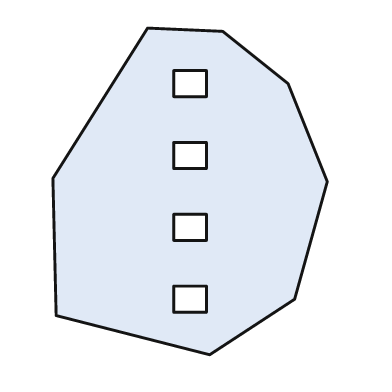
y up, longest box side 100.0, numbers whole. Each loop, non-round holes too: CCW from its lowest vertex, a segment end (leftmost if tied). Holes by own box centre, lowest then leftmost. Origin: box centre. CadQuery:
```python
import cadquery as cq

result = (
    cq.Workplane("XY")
    .moveTo(6.0, -50.0)
    .lineTo(32.0, -33.0)
    .lineTo(42.0, 3.0)
    .lineTo(30.0, 33.0)
    .lineTo(10.0, 49.0)
    .lineTo(-13.0, 50.0)
    .lineTo(-42.0, 4.0)
    .lineTo(-41.0, -38.0)
    .close()
    .moveTo(-5.0, -37.0)
    .lineTo(5.0, -37.0)
    .lineTo(5.0, -29.0)
    .lineTo(-5.0, -29.0)
    .close()
    .moveTo(-5.0, -15.0)
    .lineTo(5.0, -15.0)
    .lineTo(5.0, -7.0)
    .lineTo(-5.0, -7.0)
    .close()
    .moveTo(-5.0, 7.0)
    .lineTo(5.0, 7.0)
    .lineTo(5.0, 15.0)
    .lineTo(-5.0, 15.0)
    .close()
    .moveTo(-5.0, 29.0)
    .lineTo(5.0, 29.0)
    .lineTo(5.0, 37.0)
    .lineTo(-5.0, 37.0)
    .close()
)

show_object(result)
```